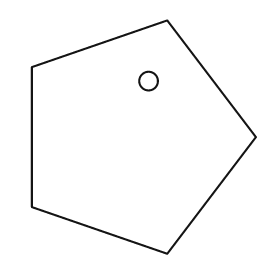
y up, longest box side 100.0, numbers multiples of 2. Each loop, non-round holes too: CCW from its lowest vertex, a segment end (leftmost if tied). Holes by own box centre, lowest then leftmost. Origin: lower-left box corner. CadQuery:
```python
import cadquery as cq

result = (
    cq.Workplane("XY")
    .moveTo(58.0, 0.0)
    .lineTo(96.0, 50.0)
    .lineTo(58.0, 100.0)
    .lineTo(0.0, 80.0)
    .lineTo(0.0, 20.0)
    .close()
    .moveTo(50.0, 74.0)
    .circle(4.0)
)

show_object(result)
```